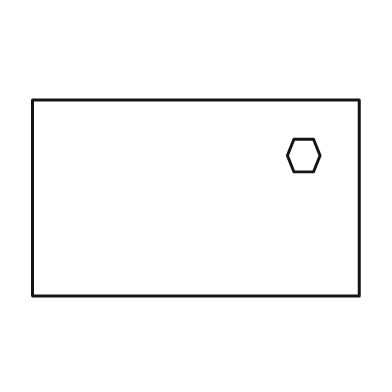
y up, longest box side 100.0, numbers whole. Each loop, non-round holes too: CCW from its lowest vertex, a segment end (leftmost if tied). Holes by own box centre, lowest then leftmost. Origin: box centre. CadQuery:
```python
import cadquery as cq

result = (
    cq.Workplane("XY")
    .moveTo(-50.0, -30.0)
    .lineTo(50.0, -30.0)
    .lineTo(50.0, 30.0)
    .lineTo(-50.0, 30.0)
    .close()
    .moveTo(30.0, 8.0)
    .lineTo(36.0, 8.0)
    .lineTo(38.0, 13.0)
    .lineTo(36.0, 18.0)
    .lineTo(30.0, 18.0)
    .lineTo(28.0, 13.0)
    .close()
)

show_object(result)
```